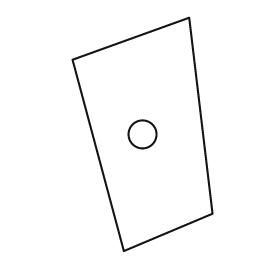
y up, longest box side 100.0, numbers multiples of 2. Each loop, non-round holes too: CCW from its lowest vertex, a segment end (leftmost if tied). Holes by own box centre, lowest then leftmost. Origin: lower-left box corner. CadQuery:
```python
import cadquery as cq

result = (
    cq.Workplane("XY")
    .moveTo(22.0, 0.0)
    .lineTo(60.0, 16.0)
    .lineTo(50.0, 100.0)
    .lineTo(0.0, 82.0)
    .close()
    .moveTo(30.0, 50.0)
    .circle(6.0)
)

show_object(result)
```